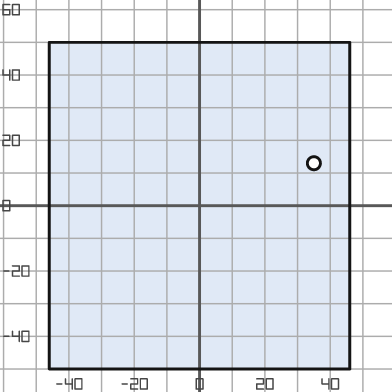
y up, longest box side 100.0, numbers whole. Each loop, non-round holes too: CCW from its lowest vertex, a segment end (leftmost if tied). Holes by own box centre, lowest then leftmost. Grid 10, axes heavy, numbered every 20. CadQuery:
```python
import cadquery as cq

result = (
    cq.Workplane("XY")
    .moveTo(-46.0, -50.0)
    .lineTo(46.0, -50.0)
    .lineTo(46.0, 50.0)
    .lineTo(-46.0, 50.0)
    .close()
    .moveTo(35.0, 13.0)
    .circle(2.0)
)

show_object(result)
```